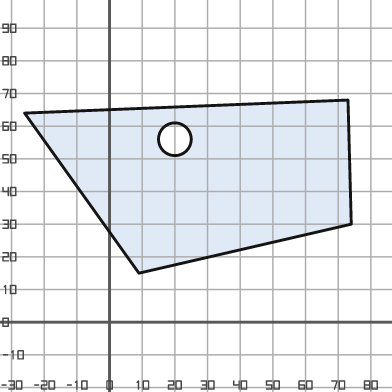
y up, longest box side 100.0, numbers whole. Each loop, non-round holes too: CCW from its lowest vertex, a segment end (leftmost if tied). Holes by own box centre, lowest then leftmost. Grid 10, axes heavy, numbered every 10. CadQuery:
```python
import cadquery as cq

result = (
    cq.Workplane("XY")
    .moveTo(9.0, 15.0)
    .lineTo(74.0, 30.0)
    .lineTo(73.0, 68.0)
    .lineTo(-26.0, 64.0)
    .close()
    .moveTo(20.0, 56.0)
    .circle(5.0)
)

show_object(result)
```